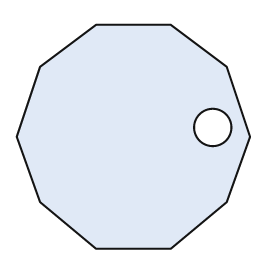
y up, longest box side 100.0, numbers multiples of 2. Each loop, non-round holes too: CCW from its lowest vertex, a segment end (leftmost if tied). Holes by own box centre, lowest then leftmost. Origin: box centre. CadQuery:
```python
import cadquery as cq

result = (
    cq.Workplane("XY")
    .moveTo(-16.0, -48.0)
    .lineTo(16.0, -48.0)
    .lineTo(40.0, -28.0)
    .lineTo(50.0, 0.0)
    .lineTo(40.0, 30.0)
    .lineTo(16.0, 48.0)
    .lineTo(-16.0, 48.0)
    .lineTo(-40.0, 30.0)
    .lineTo(-50.0, 0.0)
    .lineTo(-40.0, -28.0)
    .close()
    .moveTo(34.0, 4.0)
    .circle(8.0)
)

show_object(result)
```